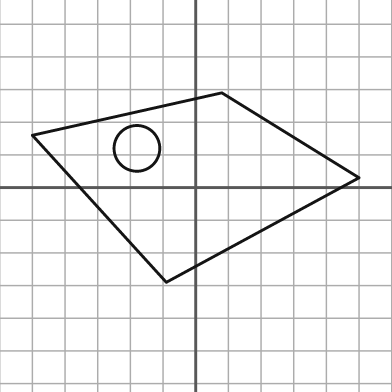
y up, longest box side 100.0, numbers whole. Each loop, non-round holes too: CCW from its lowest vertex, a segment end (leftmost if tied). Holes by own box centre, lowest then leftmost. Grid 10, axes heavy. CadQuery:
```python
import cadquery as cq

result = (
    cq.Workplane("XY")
    .moveTo(-9.0, -29.0)
    .lineTo(50.0, 3.0)
    .lineTo(8.0, 29.0)
    .lineTo(-50.0, 16.0)
    .close()
    .moveTo(-18.0, 12.0)
    .circle(7.0)
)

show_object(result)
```